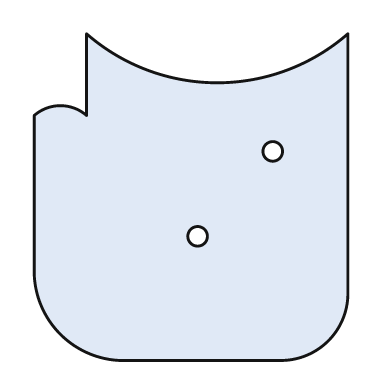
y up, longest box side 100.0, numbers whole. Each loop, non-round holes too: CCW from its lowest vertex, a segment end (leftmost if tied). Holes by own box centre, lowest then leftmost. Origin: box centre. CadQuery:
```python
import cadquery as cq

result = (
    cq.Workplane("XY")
    .moveTo(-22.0, -50.0)
    .lineTo(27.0, -50.0)
    .threePointArc((42.0, -44.0), (48.0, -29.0))
    .lineTo(48.0, 50.0)
    .threePointArc((8.0, 35.0), (-32.0, 50.0))
    .lineTo(-32.0, 25.0)
    .threePointArc((-40.0, 28.0), (-48.0, 25.0))
    .lineTo(-48.0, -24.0)
    .threePointArc((-40.0, -42.0), (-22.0, -50.0))
    .close()
    .moveTo(2.0, -12.0)
    .circle(3.0)
    .moveTo(25.0, 14.0)
    .circle(3.0)
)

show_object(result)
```